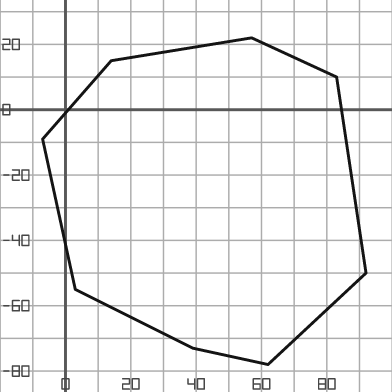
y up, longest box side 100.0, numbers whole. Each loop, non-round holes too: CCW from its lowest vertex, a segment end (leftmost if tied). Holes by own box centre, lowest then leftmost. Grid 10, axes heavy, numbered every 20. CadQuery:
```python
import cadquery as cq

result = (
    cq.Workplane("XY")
    .moveTo(62.0, -78.0)
    .lineTo(92.0, -50.0)
    .lineTo(83.0, 10.0)
    .lineTo(57.0, 22.0)
    .lineTo(14.0, 15.0)
    .lineTo(-7.0, -9.0)
    .lineTo(3.0, -55.0)
    .lineTo(39.0, -73.0)
    .close()
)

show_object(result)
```